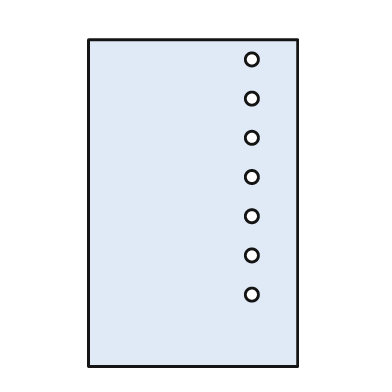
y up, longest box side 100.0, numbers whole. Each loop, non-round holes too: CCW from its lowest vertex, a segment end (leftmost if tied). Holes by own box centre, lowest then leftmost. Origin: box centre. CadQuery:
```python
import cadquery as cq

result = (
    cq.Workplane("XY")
    .moveTo(-32.0, -50.0)
    .lineTo(32.0, -50.0)
    .lineTo(32.0, 50.0)
    .lineTo(-32.0, 50.0)
    .close()
    .moveTo(18.0, -28.0)
    .circle(2.0)
    .moveTo(18.0, -16.0)
    .circle(2.0)
    .moveTo(18.0, -4.0)
    .circle(2.0)
    .moveTo(18.0, 8.0)
    .circle(2.0)
    .moveTo(18.0, 20.0)
    .circle(2.0)
    .moveTo(18.0, 32.0)
    .circle(2.0)
    .moveTo(18.0, 44.0)
    .circle(2.0)
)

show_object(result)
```